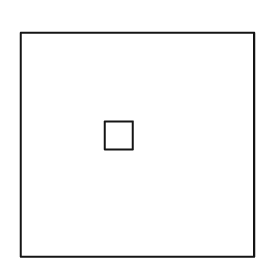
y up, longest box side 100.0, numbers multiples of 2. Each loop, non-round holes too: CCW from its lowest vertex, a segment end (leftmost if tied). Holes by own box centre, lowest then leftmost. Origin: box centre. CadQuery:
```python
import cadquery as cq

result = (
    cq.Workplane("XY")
    .moveTo(-50.0, -48.0)
    .lineTo(50.0, -48.0)
    .lineTo(50.0, 48.0)
    .lineTo(-50.0, 48.0)
    .close()
    .moveTo(-14.0, -2.0)
    .lineTo(-2.0, -2.0)
    .lineTo(-2.0, 10.0)
    .lineTo(-14.0, 10.0)
    .close()
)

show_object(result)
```